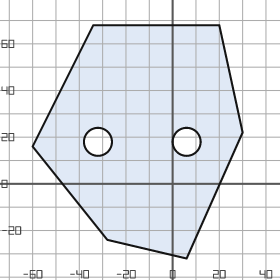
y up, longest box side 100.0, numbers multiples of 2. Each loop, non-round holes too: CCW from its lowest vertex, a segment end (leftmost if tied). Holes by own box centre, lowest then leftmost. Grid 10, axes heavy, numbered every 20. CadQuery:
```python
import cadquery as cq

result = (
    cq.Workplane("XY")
    .moveTo(6.0, -32.0)
    .lineTo(30.0, 22.0)
    .lineTo(20.0, 68.0)
    .lineTo(-34.0, 68.0)
    .lineTo(-60.0, 16.0)
    .lineTo(-28.0, -24.0)
    .close()
    .moveTo(-32.0, 18.0)
    .circle(6.0)
    .moveTo(6.0, 18.0)
    .circle(6.0)
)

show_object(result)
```